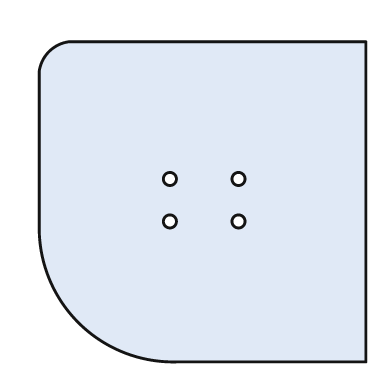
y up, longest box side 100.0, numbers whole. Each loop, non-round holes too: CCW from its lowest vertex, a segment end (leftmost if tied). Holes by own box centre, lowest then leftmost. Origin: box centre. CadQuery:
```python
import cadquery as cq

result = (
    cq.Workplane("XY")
    .moveTo(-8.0, -49.0)
    .lineTo(50.0, -49.0)
    .lineTo(50.0, 49.0)
    .lineTo(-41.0, 49.0)
    .threePointArc((-47.0, 46.0), (-50.0, 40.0))
    .lineTo(-50.0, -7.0)
    .threePointArc((-38.0, -37.0), (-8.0, -49.0))
    .close()
    .moveTo(-10.0, -6.0)
    .circle(2.0)
    .moveTo(11.0, -6.0)
    .circle(2.0)
    .moveTo(-10.0, 7.0)
    .circle(2.0)
    .moveTo(11.0, 7.0)
    .circle(2.0)
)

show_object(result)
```